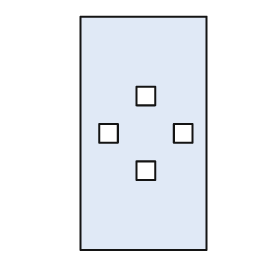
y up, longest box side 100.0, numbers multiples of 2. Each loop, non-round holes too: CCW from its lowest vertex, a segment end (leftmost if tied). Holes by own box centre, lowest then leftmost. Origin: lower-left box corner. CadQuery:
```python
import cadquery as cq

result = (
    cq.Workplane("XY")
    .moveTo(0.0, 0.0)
    .lineTo(54.0, 0.0)
    .lineTo(54.0, 100.0)
    .lineTo(0.0, 100.0)
    .close()
    .moveTo(24.0, 30.0)
    .lineTo(32.0, 30.0)
    .lineTo(32.0, 38.0)
    .lineTo(24.0, 38.0)
    .close()
    .moveTo(8.0, 46.0)
    .lineTo(16.0, 46.0)
    .lineTo(16.0, 54.0)
    .lineTo(8.0, 54.0)
    .close()
    .moveTo(40.0, 46.0)
    .lineTo(48.0, 46.0)
    .lineTo(48.0, 54.0)
    .lineTo(40.0, 54.0)
    .close()
    .moveTo(24.0, 62.0)
    .lineTo(32.0, 62.0)
    .lineTo(32.0, 70.0)
    .lineTo(24.0, 70.0)
    .close()
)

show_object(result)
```